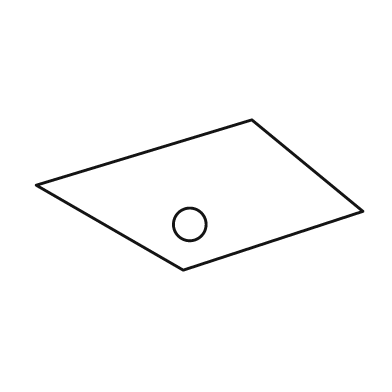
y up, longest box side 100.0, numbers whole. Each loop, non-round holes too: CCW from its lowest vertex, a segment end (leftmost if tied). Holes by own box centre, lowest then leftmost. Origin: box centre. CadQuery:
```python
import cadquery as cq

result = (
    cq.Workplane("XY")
    .moveTo(-5.0, -23.0)
    .lineTo(50.0, -5.0)
    .lineTo(16.0, 23.0)
    .lineTo(-50.0, 3.0)
    .close()
    .moveTo(-3.0, -9.0)
    .circle(5.0)
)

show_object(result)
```